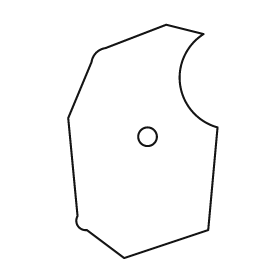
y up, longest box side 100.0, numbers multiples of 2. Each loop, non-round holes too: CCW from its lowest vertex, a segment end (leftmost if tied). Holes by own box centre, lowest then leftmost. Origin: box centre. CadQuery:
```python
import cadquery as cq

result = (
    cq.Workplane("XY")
    .moveTo(-8.0, -50.0)
    .lineTo(28.0, -38.0)
    .lineTo(32.0, 6.0)
    .threePointArc((16.0, 24.0), (26.0, 46.0))
    .lineTo(10.0, 50.0)
    .lineTo(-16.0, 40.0)
    .threePointArc((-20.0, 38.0), (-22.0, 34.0))
    .lineTo(-32.0, 10.0)
    .lineTo(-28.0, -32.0)
    .threePointArc((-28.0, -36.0), (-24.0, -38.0))
    .close()
    .moveTo(2.0, 2.0)
    .circle(4.0)
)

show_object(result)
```